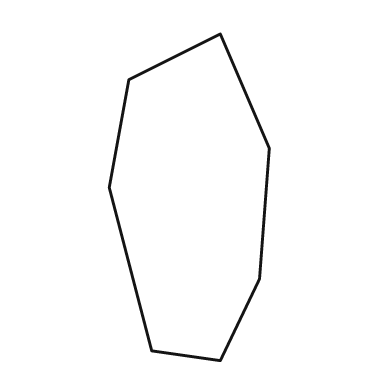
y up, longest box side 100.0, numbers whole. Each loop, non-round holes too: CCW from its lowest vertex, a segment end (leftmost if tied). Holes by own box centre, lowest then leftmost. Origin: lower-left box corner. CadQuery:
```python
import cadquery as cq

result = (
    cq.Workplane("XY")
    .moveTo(34.0, 0.0)
    .lineTo(46.0, 25.0)
    .lineTo(49.0, 65.0)
    .lineTo(34.0, 100.0)
    .lineTo(6.0, 86.0)
    .lineTo(0.0, 53.0)
    .lineTo(13.0, 3.0)
    .close()
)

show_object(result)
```